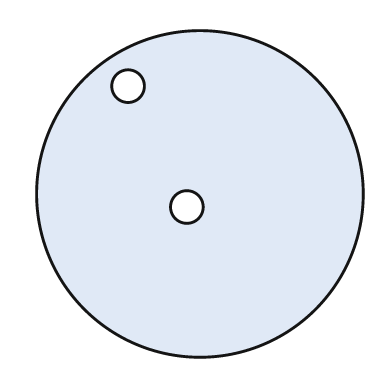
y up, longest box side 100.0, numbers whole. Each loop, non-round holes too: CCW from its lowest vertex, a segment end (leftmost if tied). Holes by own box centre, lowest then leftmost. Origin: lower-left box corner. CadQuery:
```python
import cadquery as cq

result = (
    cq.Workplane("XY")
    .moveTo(50.0, 50.0)
    .circle(50.0)
    .moveTo(46.0, 46.0)
    .circle(5.0)
    .moveTo(28.0, 83.0)
    .circle(5.0)
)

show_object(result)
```